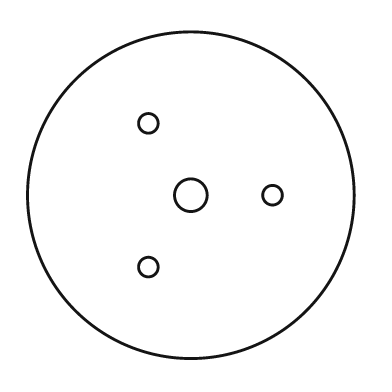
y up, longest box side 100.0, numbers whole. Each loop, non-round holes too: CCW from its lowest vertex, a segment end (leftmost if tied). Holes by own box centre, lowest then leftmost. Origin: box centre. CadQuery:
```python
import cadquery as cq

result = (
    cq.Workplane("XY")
    .moveTo(0.0, 0.0)
    .circle(50.0)
    .moveTo(-13.0, -22.0)
    .circle(3.0)
    .moveTo(0.0, 0.0)
    .circle(5.0)
    .moveTo(25.0, 0.0)
    .circle(3.0)
    .moveTo(-13.0, 22.0)
    .circle(3.0)
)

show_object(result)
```